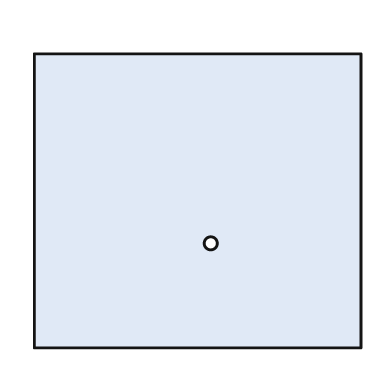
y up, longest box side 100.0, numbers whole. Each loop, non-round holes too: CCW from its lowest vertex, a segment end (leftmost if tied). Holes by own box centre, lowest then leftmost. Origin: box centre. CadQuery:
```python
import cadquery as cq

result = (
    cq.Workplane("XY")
    .moveTo(-50.0, -45.0)
    .lineTo(50.0, -45.0)
    .lineTo(50.0, 45.0)
    .lineTo(-50.0, 45.0)
    .close()
    .moveTo(4.0, -13.0)
    .circle(2.0)
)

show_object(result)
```